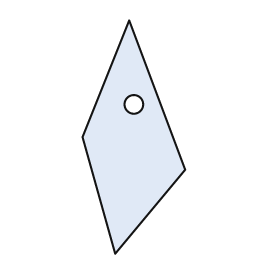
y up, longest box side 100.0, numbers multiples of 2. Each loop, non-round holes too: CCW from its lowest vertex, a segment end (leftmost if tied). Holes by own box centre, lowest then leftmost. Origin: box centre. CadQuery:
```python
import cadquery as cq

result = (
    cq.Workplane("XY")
    .moveTo(-8.0, -50.0)
    .lineTo(22.0, -14.0)
    .lineTo(-2.0, 50.0)
    .lineTo(-22.0, 0.0)
    .close()
    .moveTo(0.0, 14.0)
    .circle(4.0)
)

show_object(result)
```